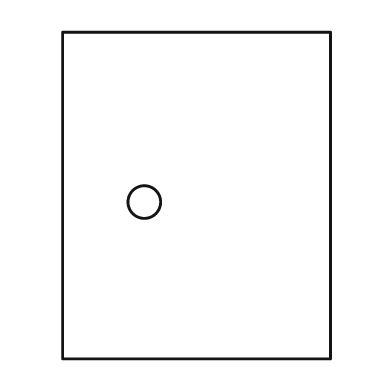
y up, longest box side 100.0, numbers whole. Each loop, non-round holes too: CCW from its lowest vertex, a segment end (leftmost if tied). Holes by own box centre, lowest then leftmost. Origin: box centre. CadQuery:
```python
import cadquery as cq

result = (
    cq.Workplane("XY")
    .moveTo(-41.0, -50.0)
    .lineTo(41.0, -50.0)
    .lineTo(41.0, 50.0)
    .lineTo(-41.0, 50.0)
    .close()
    .moveTo(-16.0, -2.0)
    .circle(5.0)
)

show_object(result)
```